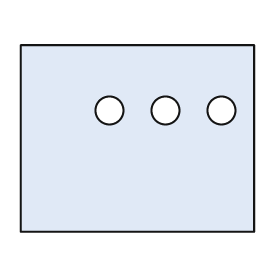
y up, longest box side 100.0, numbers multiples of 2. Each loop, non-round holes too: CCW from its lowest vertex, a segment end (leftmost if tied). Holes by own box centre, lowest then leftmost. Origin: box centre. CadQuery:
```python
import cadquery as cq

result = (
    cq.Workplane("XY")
    .moveTo(-50.0, -40.0)
    .lineTo(50.0, -40.0)
    .lineTo(50.0, 40.0)
    .lineTo(-50.0, 40.0)
    .close()
    .moveTo(-12.0, 12.0)
    .circle(6.0)
    .moveTo(12.0, 12.0)
    .circle(6.0)
    .moveTo(36.0, 12.0)
    .circle(6.0)
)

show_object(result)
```